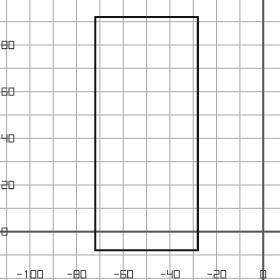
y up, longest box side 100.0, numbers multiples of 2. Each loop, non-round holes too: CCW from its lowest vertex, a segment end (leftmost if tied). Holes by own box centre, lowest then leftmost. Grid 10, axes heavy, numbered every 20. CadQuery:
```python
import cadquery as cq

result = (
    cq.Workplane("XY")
    .moveTo(-72.0, -8.0)
    .lineTo(-28.0, -8.0)
    .lineTo(-28.0, 92.0)
    .lineTo(-72.0, 92.0)
    .close()
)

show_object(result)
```